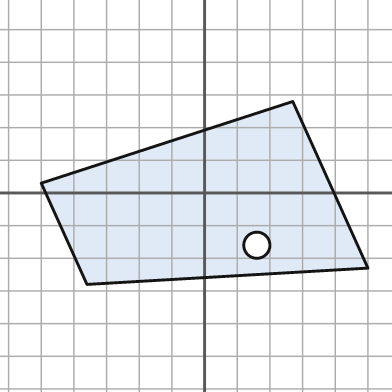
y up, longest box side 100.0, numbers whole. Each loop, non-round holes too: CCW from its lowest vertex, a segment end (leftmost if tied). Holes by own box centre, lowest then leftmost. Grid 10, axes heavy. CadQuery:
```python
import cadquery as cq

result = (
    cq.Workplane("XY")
    .moveTo(-36.0, -28.0)
    .lineTo(50.0, -23.0)
    .lineTo(27.0, 28.0)
    .lineTo(-50.0, 3.0)
    .close()
    .moveTo(16.0, -16.0)
    .circle(4.0)
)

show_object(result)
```